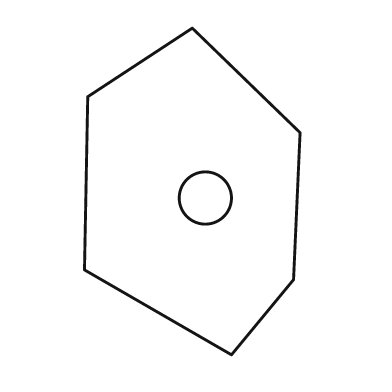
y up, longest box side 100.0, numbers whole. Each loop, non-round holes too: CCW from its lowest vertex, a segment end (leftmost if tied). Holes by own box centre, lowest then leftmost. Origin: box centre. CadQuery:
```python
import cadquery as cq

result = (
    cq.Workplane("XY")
    .moveTo(12.0, -50.0)
    .lineTo(31.0, -27.0)
    .lineTo(33.0, 18.0)
    .lineTo(0.0, 50.0)
    .lineTo(-32.0, 29.0)
    .lineTo(-33.0, -24.0)
    .close()
    .moveTo(4.0, -2.0)
    .circle(8.0)
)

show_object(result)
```